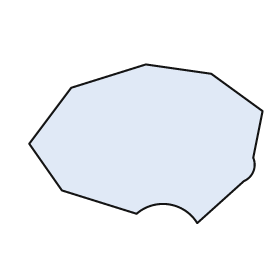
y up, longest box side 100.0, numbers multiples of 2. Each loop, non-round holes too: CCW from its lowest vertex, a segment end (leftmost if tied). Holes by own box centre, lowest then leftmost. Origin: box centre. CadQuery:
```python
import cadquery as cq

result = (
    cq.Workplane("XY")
    .moveTo(22.0, -34.0)
    .lineTo(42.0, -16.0)
    .threePointArc((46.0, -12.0), (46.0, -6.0))
    .lineTo(50.0, 14.0)
    .lineTo(28.0, 30.0)
    .lineTo(0.0, 34.0)
    .lineTo(-32.0, 24.0)
    .lineTo(-50.0, 0.0)
    .lineTo(-36.0, -20.0)
    .lineTo(-4.0, -30.0)
    .threePointArc((10.0, -26.0), (22.0, -34.0))
    .close()
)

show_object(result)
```